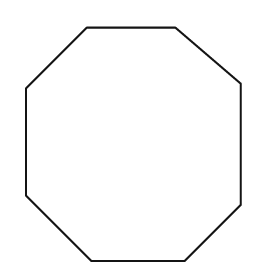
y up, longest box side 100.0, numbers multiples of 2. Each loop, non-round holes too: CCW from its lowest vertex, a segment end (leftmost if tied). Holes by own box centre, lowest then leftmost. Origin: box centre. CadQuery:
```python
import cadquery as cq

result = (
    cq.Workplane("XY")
    .moveTo(-18.0, -50.0)
    .lineTo(22.0, -50.0)
    .lineTo(46.0, -26.0)
    .lineTo(46.0, 26.0)
    .lineTo(18.0, 50.0)
    .lineTo(-20.0, 50.0)
    .lineTo(-46.0, 24.0)
    .lineTo(-46.0, -22.0)
    .close()
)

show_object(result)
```